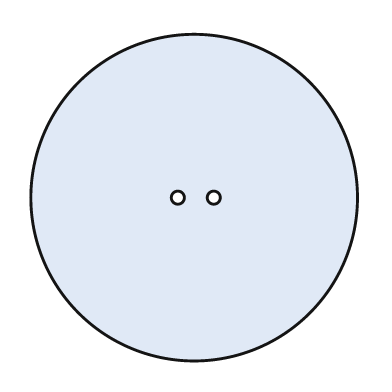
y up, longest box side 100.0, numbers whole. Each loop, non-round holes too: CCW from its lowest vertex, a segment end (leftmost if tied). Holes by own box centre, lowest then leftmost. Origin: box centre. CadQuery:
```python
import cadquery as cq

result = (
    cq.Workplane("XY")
    .moveTo(0.0, 0.0)
    .circle(50.0)
    .moveTo(-5.0, 0.0)
    .circle(2.0)
    .moveTo(6.0, 0.0)
    .circle(2.0)
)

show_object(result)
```